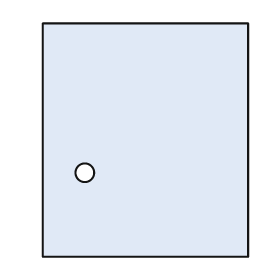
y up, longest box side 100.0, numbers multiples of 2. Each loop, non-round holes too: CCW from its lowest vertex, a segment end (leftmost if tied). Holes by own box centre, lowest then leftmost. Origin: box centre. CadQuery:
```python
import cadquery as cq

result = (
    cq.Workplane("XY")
    .moveTo(-44.0, -50.0)
    .lineTo(44.0, -50.0)
    .lineTo(44.0, 50.0)
    .lineTo(-44.0, 50.0)
    .close()
    .moveTo(-26.0, -14.0)
    .circle(4.0)
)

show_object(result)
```